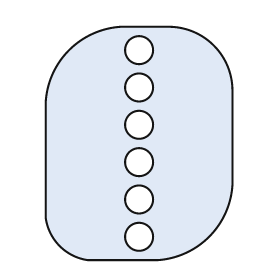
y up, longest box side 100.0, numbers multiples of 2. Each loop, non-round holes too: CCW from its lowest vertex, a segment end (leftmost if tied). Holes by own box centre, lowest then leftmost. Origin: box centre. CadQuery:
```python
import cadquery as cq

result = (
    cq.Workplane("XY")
    .moveTo(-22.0, -50.0)
    .lineTo(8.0, -50.0)
    .threePointArc((30.0, -40.0), (40.0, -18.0))
    .lineTo(40.0, 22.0)
    .threePointArc((32.0, 42.0), (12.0, 50.0))
    .lineTo(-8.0, 50.0)
    .threePointArc((-30.0, 40.0), (-40.0, 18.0))
    .lineTo(-40.0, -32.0)
    .threePointArc((-34.0, -44.0), (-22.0, -50.0))
    .close()
    .moveTo(0.0, -40.0)
    .circle(6.0)
    .moveTo(0.0, -24.0)
    .circle(6.0)
    .moveTo(0.0, -8.0)
    .circle(6.0)
    .moveTo(0.0, 8.0)
    .circle(6.0)
    .moveTo(0.0, 24.0)
    .circle(6.0)
    .moveTo(0.0, 40.0)
    .circle(6.0)
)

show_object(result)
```